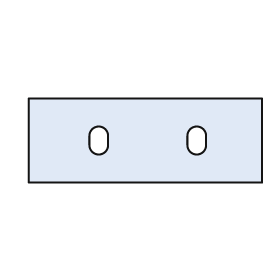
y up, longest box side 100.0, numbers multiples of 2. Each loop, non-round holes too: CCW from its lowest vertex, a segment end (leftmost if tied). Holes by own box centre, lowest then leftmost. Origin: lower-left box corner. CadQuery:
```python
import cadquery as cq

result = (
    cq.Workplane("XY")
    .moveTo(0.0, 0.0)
    .lineTo(100.0, 0.0)
    .lineTo(100.0, 36.0)
    .lineTo(0.0, 36.0)
    .close()
    .moveTo(26.0, 16.0)
    .threePointArc((30.0, 12.0), (34.0, 16.0))
    .lineTo(34.0, 20.0)
    .threePointArc((30.0, 24.0), (26.0, 20.0))
    .close()
    .moveTo(68.0, 16.0)
    .threePointArc((72.0, 12.0), (76.0, 16.0))
    .lineTo(76.0, 20.0)
    .threePointArc((72.0, 24.0), (68.0, 20.0))
    .close()
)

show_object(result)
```